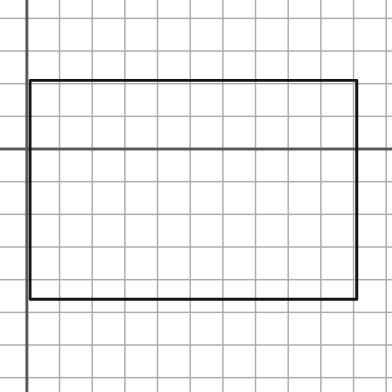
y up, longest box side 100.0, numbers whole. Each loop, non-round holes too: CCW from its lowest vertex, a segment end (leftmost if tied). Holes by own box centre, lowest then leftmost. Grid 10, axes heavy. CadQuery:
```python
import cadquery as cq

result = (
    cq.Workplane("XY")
    .moveTo(1.0, -46.0)
    .lineTo(101.0, -46.0)
    .lineTo(101.0, 21.0)
    .lineTo(1.0, 21.0)
    .close()
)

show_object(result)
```